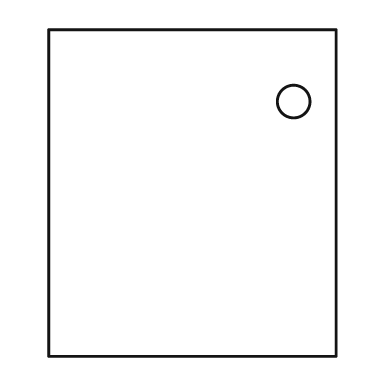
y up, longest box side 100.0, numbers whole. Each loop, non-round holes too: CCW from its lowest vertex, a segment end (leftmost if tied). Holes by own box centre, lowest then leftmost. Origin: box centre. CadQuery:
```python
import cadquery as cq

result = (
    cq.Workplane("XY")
    .moveTo(-44.0, -50.0)
    .lineTo(44.0, -50.0)
    .lineTo(44.0, 50.0)
    .lineTo(-44.0, 50.0)
    .close()
    .moveTo(31.0, 28.0)
    .circle(5.0)
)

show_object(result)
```